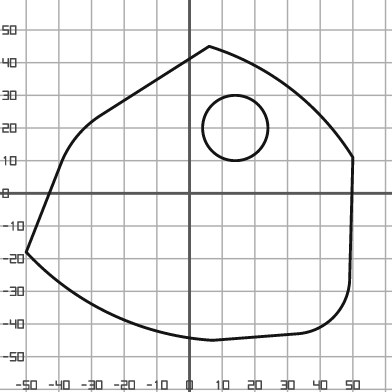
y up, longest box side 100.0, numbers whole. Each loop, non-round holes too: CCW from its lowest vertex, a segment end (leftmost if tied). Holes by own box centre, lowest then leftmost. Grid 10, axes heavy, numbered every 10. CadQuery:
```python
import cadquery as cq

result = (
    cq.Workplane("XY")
    .moveTo(7.0, -45.0)
    .lineTo(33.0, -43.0)
    .threePointArc((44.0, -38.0), (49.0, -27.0))
    .lineTo(50.0, 11.0)
    .threePointArc((31.0, 32.0), (6.0, 45.0))
    .lineTo(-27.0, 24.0)
    .threePointArc((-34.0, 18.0), (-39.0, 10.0))
    .lineTo(-50.0, -18.0)
    .threePointArc((-24.0, -37.0), (7.0, -45.0))
    .close()
    .moveTo(14.0, 20.0)
    .circle(10.0)
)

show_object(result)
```